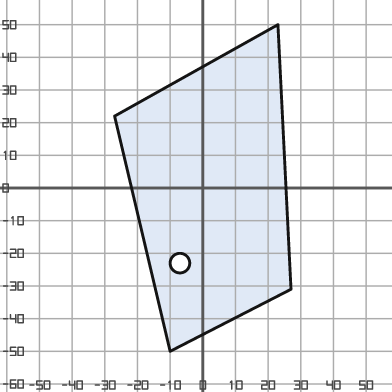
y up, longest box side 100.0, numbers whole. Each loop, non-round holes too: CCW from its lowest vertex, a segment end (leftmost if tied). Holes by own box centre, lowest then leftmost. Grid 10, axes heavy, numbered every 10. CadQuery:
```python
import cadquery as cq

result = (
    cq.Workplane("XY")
    .moveTo(-10.0, -50.0)
    .lineTo(27.0, -31.0)
    .lineTo(23.0, 50.0)
    .lineTo(-27.0, 22.0)
    .close()
    .moveTo(-7.0, -23.0)
    .circle(3.0)
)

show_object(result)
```